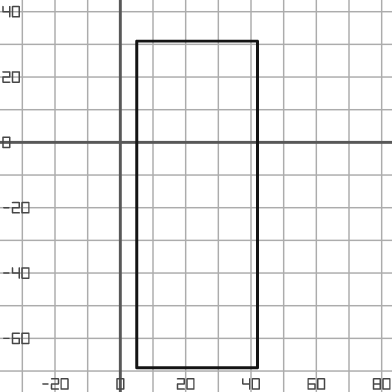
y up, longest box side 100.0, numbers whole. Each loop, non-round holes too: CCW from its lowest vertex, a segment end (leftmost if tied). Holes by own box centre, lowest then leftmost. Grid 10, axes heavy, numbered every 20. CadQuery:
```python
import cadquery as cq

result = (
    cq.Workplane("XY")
    .moveTo(5.0, -69.0)
    .lineTo(42.0, -69.0)
    .lineTo(42.0, 31.0)
    .lineTo(5.0, 31.0)
    .close()
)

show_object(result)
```